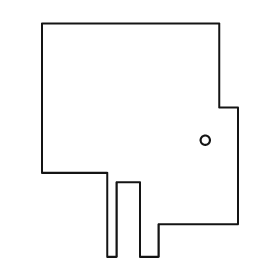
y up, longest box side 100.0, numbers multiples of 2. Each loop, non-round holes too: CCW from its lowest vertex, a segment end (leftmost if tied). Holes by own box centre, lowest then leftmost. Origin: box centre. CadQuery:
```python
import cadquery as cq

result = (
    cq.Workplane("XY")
    .moveTo(-14.0, -50.0)
    .lineTo(-10.0, -50.0)
    .lineTo(-10.0, -18.0)
    .lineTo(0.0, -18.0)
    .lineTo(0.0, -50.0)
    .lineTo(8.0, -50.0)
    .lineTo(8.0, -36.0)
    .lineTo(42.0, -36.0)
    .lineTo(42.0, 14.0)
    .lineTo(34.0, 14.0)
    .lineTo(34.0, 50.0)
    .lineTo(-42.0, 50.0)
    .lineTo(-42.0, -14.0)
    .lineTo(-14.0, -14.0)
    .close()
    .moveTo(28.0, 0.0)
    .circle(2.0)
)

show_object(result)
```